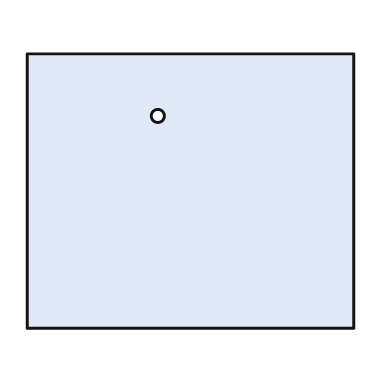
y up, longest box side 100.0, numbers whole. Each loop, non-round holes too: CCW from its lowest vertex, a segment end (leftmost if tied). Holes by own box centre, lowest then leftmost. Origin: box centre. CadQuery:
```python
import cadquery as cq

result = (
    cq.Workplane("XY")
    .moveTo(-50.0, -42.0)
    .lineTo(50.0, -42.0)
    .lineTo(50.0, 42.0)
    .lineTo(-50.0, 42.0)
    .close()
    .moveTo(-10.0, 23.0)
    .circle(2.0)
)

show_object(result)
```